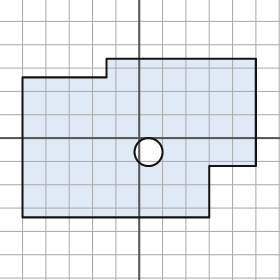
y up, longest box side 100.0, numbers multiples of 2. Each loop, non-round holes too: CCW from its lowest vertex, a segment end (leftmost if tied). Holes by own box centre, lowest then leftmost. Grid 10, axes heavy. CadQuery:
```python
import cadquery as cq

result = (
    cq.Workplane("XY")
    .moveTo(-50.0, -34.0)
    .lineTo(30.0, -34.0)
    .lineTo(30.0, -12.0)
    .lineTo(50.0, -12.0)
    .lineTo(50.0, 34.0)
    .lineTo(-14.0, 34.0)
    .lineTo(-14.0, 26.0)
    .lineTo(-50.0, 26.0)
    .close()
    .moveTo(4.0, -6.0)
    .circle(6.0)
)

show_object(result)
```